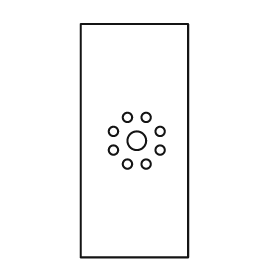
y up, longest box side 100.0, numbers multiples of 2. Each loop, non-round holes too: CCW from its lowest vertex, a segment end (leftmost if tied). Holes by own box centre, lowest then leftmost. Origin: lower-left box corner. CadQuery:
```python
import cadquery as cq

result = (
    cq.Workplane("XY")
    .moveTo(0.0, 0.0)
    .lineTo(46.0, 0.0)
    .lineTo(46.0, 100.0)
    .lineTo(0.0, 100.0)
    .close()
    .moveTo(20.0, 40.0)
    .circle(2.0)
    .moveTo(28.0, 40.0)
    .circle(2.0)
    .moveTo(14.0, 46.0)
    .circle(2.0)
    .moveTo(34.0, 46.0)
    .circle(2.0)
    .moveTo(24.0, 50.0)
    .circle(4.0)
    .moveTo(14.0, 54.0)
    .circle(2.0)
    .moveTo(34.0, 54.0)
    .circle(2.0)
    .moveTo(20.0, 60.0)
    .circle(2.0)
    .moveTo(28.0, 60.0)
    .circle(2.0)
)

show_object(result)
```